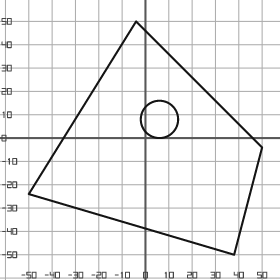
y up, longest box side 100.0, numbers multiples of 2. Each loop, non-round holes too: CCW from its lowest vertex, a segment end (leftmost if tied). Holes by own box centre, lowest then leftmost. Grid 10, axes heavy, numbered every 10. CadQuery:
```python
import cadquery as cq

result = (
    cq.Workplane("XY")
    .moveTo(38.0, -50.0)
    .lineTo(50.0, -4.0)
    .lineTo(-4.0, 50.0)
    .lineTo(-50.0, -24.0)
    .close()
    .moveTo(6.0, 8.0)
    .circle(8.0)
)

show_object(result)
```